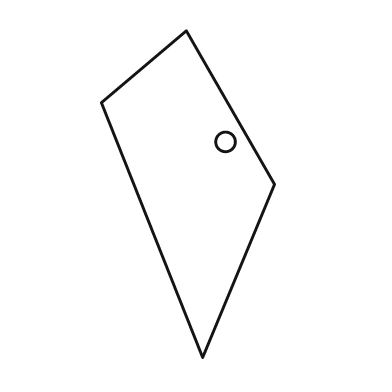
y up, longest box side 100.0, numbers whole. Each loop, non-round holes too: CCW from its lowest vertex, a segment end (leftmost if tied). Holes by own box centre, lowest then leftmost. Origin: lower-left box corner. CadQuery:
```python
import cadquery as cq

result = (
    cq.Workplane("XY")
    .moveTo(31.0, 0.0)
    .lineTo(53.0, 53.0)
    .lineTo(26.0, 100.0)
    .lineTo(0.0, 78.0)
    .close()
    .moveTo(38.0, 66.0)
    .circle(3.0)
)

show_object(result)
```